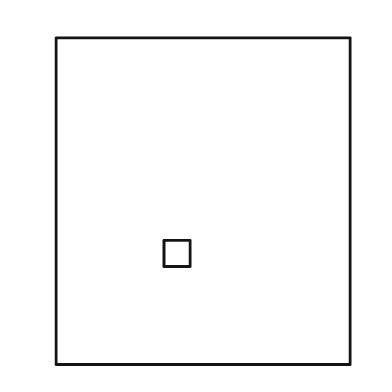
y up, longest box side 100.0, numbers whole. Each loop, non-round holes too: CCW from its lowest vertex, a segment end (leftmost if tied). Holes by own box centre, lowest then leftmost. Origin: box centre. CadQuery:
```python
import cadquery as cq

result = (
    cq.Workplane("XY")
    .moveTo(-45.0, -50.0)
    .lineTo(45.0, -50.0)
    .lineTo(45.0, 50.0)
    .lineTo(-45.0, 50.0)
    .close()
    .moveTo(-12.0, -20.0)
    .lineTo(-4.0, -20.0)
    .lineTo(-4.0, -12.0)
    .lineTo(-12.0, -12.0)
    .close()
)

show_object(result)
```